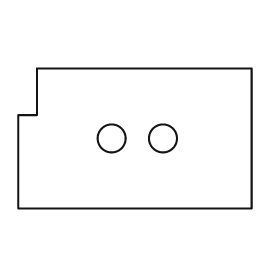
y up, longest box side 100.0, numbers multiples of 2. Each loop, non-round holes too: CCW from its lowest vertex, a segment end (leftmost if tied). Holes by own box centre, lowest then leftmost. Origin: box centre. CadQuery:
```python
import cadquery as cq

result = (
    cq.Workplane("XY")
    .moveTo(-50.0, -30.0)
    .lineTo(50.0, -30.0)
    .lineTo(50.0, 30.0)
    .lineTo(-42.0, 30.0)
    .lineTo(-42.0, 10.0)
    .lineTo(-50.0, 10.0)
    .close()
    .moveTo(-10.0, 0.0)
    .circle(6.0)
    .moveTo(12.0, 0.0)
    .circle(6.0)
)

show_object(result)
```